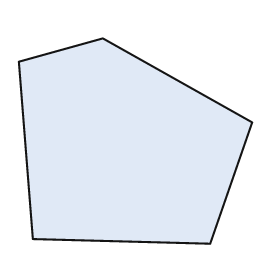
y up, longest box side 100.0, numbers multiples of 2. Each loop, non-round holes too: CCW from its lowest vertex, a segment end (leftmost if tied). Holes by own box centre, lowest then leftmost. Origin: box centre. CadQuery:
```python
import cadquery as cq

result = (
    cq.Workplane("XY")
    .moveTo(32.0, -44.0)
    .lineTo(50.0, 8.0)
    .lineTo(-14.0, 44.0)
    .lineTo(-50.0, 34.0)
    .lineTo(-44.0, -42.0)
    .close()
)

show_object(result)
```